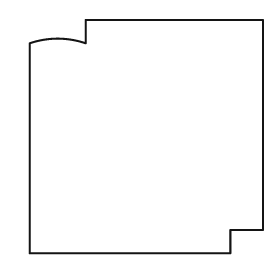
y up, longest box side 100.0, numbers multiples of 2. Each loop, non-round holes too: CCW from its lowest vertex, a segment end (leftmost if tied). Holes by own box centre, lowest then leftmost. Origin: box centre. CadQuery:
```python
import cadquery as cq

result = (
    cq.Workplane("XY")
    .moveTo(-50.0, -50.0)
    .lineTo(36.0, -50.0)
    .lineTo(36.0, -40.0)
    .lineTo(50.0, -40.0)
    .lineTo(50.0, 50.0)
    .lineTo(-26.0, 50.0)
    .lineTo(-26.0, 40.0)
    .threePointArc((-38.0, 42.0), (-50.0, 40.0))
    .close()
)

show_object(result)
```